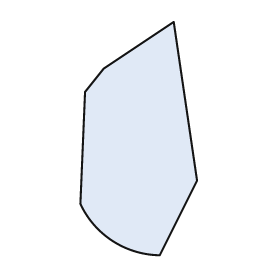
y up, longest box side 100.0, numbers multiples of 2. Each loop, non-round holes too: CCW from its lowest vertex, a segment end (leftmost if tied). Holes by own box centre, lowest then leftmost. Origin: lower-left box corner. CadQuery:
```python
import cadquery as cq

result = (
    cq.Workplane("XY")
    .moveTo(34.0, 0.0)
    .lineTo(50.0, 32.0)
    .lineTo(40.0, 100.0)
    .lineTo(10.0, 80.0)
    .lineTo(2.0, 70.0)
    .lineTo(0.0, 22.0)
    .threePointArc((14.0, 6.0), (34.0, 0.0))
    .close()
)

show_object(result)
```